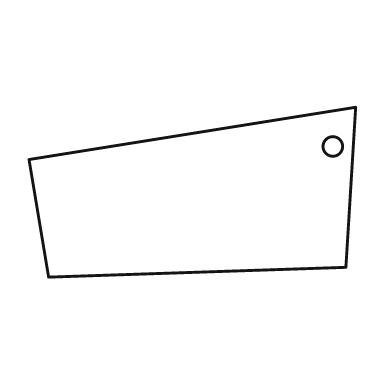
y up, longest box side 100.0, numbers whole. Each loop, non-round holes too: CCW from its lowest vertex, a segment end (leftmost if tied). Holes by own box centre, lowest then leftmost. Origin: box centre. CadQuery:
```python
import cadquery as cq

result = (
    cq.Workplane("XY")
    .moveTo(-44.0, -26.0)
    .lineTo(47.0, -23.0)
    .lineTo(50.0, 26.0)
    .lineTo(-50.0, 10.0)
    .close()
    .moveTo(43.0, 14.0)
    .circle(3.0)
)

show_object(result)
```